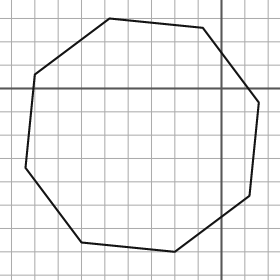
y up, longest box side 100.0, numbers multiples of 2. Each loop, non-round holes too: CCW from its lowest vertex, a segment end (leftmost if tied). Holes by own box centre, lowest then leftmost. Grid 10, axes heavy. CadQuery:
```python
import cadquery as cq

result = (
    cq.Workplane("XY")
    .moveTo(-20.0, -70.0)
    .lineTo(12.0, -46.0)
    .lineTo(16.0, -6.0)
    .lineTo(-8.0, 26.0)
    .lineTo(-48.0, 30.0)
    .lineTo(-80.0, 6.0)
    .lineTo(-84.0, -34.0)
    .lineTo(-60.0, -66.0)
    .close()
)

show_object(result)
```